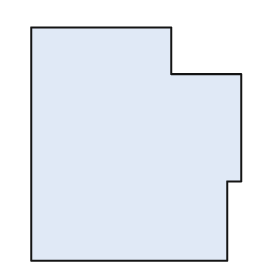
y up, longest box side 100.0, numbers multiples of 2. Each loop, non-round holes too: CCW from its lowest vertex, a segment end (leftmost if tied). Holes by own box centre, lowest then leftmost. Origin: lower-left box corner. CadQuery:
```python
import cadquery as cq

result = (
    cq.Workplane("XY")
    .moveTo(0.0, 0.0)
    .lineTo(84.0, 0.0)
    .lineTo(84.0, 34.0)
    .lineTo(90.0, 34.0)
    .lineTo(90.0, 80.0)
    .lineTo(60.0, 80.0)
    .lineTo(60.0, 100.0)
    .lineTo(0.0, 100.0)
    .close()
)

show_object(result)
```